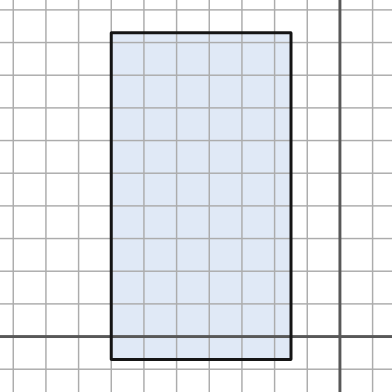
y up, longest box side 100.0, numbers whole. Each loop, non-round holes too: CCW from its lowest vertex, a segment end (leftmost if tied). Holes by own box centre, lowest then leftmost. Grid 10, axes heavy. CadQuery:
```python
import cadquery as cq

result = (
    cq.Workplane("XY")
    .moveTo(-70.0, -7.0)
    .lineTo(-15.0, -7.0)
    .lineTo(-15.0, 93.0)
    .lineTo(-70.0, 93.0)
    .close()
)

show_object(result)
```